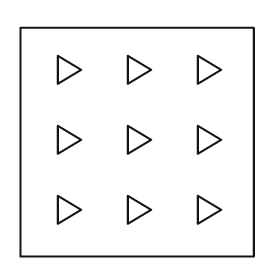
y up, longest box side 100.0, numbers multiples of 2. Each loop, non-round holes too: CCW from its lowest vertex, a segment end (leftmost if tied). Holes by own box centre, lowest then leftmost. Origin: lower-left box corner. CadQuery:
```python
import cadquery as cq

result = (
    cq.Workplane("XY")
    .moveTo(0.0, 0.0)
    .lineTo(100.0, 0.0)
    .lineTo(100.0, 98.0)
    .lineTo(0.0, 98.0)
    .close()
    .moveTo(16.0, 14.0)
    .lineTo(26.0, 20.0)
    .lineTo(16.0, 26.0)
    .close()
    .moveTo(46.0, 14.0)
    .lineTo(56.0, 20.0)
    .lineTo(46.0, 26.0)
    .close()
    .moveTo(76.0, 14.0)
    .lineTo(86.0, 20.0)
    .lineTo(76.0, 26.0)
    .close()
    .moveTo(16.0, 44.0)
    .lineTo(26.0, 50.0)
    .lineTo(16.0, 56.0)
    .close()
    .moveTo(46.0, 44.0)
    .lineTo(56.0, 50.0)
    .lineTo(46.0, 56.0)
    .close()
    .moveTo(76.0, 44.0)
    .lineTo(86.0, 50.0)
    .lineTo(76.0, 56.0)
    .close()
    .moveTo(16.0, 74.0)
    .lineTo(26.0, 80.0)
    .lineTo(16.0, 86.0)
    .close()
    .moveTo(46.0, 74.0)
    .lineTo(56.0, 80.0)
    .lineTo(46.0, 86.0)
    .close()
    .moveTo(76.0, 74.0)
    .lineTo(86.0, 80.0)
    .lineTo(76.0, 86.0)
    .close()
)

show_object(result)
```